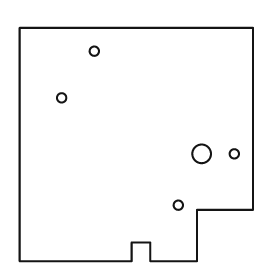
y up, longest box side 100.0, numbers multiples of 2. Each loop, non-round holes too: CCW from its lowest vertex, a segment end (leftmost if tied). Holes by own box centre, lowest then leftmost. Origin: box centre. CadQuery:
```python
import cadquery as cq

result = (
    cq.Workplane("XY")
    .moveTo(-50.0, -50.0)
    .lineTo(-2.0, -50.0)
    .lineTo(-2.0, -42.0)
    .lineTo(6.0, -42.0)
    .lineTo(6.0, -50.0)
    .lineTo(26.0, -50.0)
    .lineTo(26.0, -28.0)
    .lineTo(50.0, -28.0)
    .lineTo(50.0, 50.0)
    .lineTo(-50.0, 50.0)
    .close()
    .moveTo(18.0, -26.0)
    .circle(2.0)
    .moveTo(28.0, -4.0)
    .circle(4.0)
    .moveTo(42.0, -4.0)
    .circle(2.0)
    .moveTo(-32.0, 20.0)
    .circle(2.0)
    .moveTo(-18.0, 40.0)
    .circle(2.0)
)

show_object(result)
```